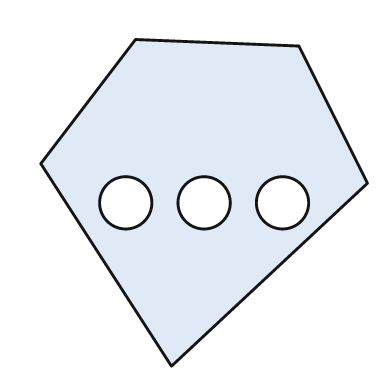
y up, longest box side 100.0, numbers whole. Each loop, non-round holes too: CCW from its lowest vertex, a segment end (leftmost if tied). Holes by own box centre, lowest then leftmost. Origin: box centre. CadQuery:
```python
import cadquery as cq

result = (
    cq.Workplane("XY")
    .moveTo(-10.0, -50.0)
    .lineTo(50.0, 6.0)
    .lineTo(29.0, 48.0)
    .lineTo(-21.0, 50.0)
    .lineTo(-50.0, 12.0)
    .close()
    .moveTo(-24.0, 0.0)
    .circle(8.0)
    .moveTo(0.0, 0.0)
    .circle(8.0)
    .moveTo(24.0, 0.0)
    .circle(8.0)
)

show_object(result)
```